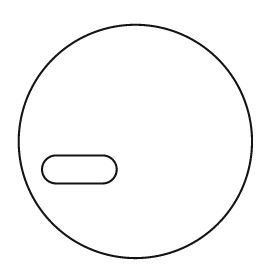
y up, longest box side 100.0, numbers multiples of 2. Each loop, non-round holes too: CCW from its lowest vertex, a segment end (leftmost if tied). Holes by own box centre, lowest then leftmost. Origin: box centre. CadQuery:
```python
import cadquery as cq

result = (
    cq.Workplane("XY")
    .moveTo(0.0, 0.0)
    .circle(50.0)
    .moveTo(-34.0, -18.0)
    .lineTo(-14.0, -18.0)
    .threePointArc((-8.0, -12.0), (-14.0, -6.0))
    .lineTo(-34.0, -6.0)
    .threePointArc((-40.0, -12.0), (-34.0, -18.0))
    .close()
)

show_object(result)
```